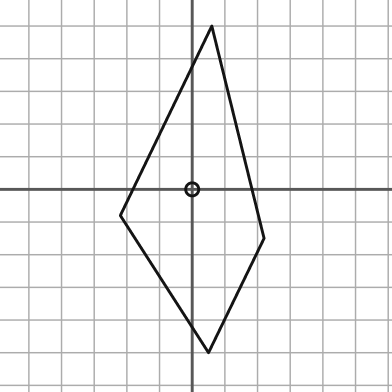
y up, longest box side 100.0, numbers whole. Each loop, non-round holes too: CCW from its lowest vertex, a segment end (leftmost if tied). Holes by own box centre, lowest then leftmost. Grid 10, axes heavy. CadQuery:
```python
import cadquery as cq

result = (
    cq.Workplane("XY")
    .moveTo(5.0, -50.0)
    .lineTo(22.0, -15.0)
    .lineTo(6.0, 50.0)
    .lineTo(-22.0, -8.0)
    .close()
    .moveTo(0.0, 0.0)
    .circle(2.0)
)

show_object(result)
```